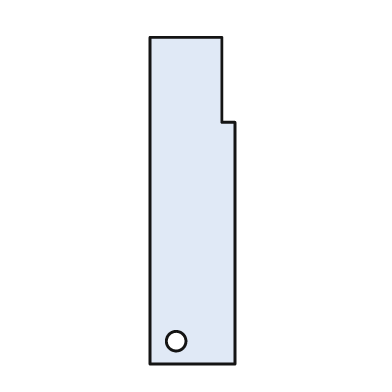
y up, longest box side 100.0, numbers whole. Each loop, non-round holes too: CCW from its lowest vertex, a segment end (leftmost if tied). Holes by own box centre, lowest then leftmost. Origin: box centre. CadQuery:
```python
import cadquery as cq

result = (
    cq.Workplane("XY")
    .moveTo(-13.0, -50.0)
    .lineTo(13.0, -50.0)
    .lineTo(13.0, 24.0)
    .lineTo(9.0, 24.0)
    .lineTo(9.0, 50.0)
    .lineTo(-13.0, 50.0)
    .close()
    .moveTo(-5.0, -43.0)
    .circle(3.0)
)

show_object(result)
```